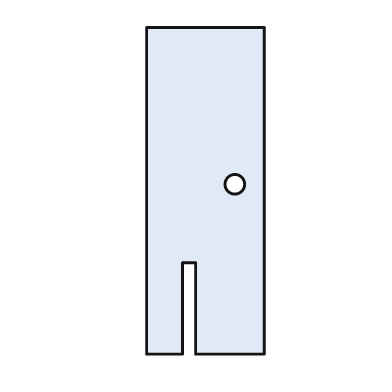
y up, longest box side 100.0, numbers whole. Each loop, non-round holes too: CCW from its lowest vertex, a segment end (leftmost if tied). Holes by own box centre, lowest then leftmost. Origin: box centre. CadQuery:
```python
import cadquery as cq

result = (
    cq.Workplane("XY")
    .moveTo(-18.0, -50.0)
    .lineTo(-7.0, -50.0)
    .lineTo(-7.0, -22.0)
    .lineTo(-3.0, -22.0)
    .lineTo(-3.0, -50.0)
    .lineTo(18.0, -50.0)
    .lineTo(18.0, 50.0)
    .lineTo(-18.0, 50.0)
    .close()
    .moveTo(9.0, 2.0)
    .circle(3.0)
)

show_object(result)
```